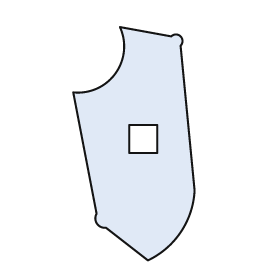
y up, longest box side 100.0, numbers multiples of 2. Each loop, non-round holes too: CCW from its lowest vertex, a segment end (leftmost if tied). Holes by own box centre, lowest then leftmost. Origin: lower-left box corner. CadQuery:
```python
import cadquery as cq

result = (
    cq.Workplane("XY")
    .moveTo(32.0, 0.0)
    .threePointArc((46.0, 12.0), (52.0, 30.0))
    .lineTo(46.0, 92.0)
    .threePointArc((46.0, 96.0), (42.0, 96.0))
    .lineTo(20.0, 100.0)
    .threePointArc((18.0, 80.0), (0.0, 72.0))
    .lineTo(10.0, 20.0)
    .threePointArc((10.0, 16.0), (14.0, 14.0))
    .close()
    .moveTo(24.0, 46.0)
    .lineTo(36.0, 46.0)
    .lineTo(36.0, 58.0)
    .lineTo(24.0, 58.0)
    .close()
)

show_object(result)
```